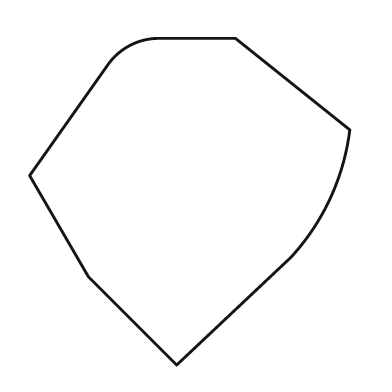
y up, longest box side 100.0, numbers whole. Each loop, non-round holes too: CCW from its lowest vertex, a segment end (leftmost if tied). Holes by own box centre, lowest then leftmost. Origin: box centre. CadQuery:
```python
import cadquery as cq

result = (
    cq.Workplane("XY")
    .moveTo(-4.0, -50.0)
    .lineTo(31.0, -17.0)
    .threePointArc((43.0, 1.0), (49.0, 22.0))
    .lineTo(14.0, 50.0)
    .lineTo(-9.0, 50.0)
    .threePointArc((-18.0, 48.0), (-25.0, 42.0))
    .lineTo(-49.0, 8.0)
    .lineTo(-31.0, -23.0)
    .close()
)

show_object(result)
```